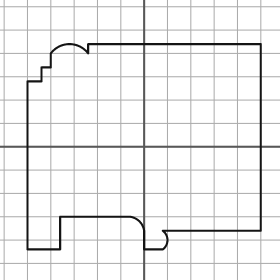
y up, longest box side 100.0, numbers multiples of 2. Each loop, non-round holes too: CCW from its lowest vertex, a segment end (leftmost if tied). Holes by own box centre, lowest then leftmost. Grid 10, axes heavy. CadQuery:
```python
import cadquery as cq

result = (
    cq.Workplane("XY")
    .moveTo(-50.0, -44.0)
    .lineTo(-36.0, -44.0)
    .lineTo(-36.0, -30.0)
    .lineTo(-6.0, -30.0)
    .threePointArc((-2.0, -32.0), (0.0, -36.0))
    .lineTo(0.0, -44.0)
    .lineTo(8.0, -44.0)
    .threePointArc((10.0, -40.0), (8.0, -36.0))
    .lineTo(50.0, -36.0)
    .lineTo(50.0, 44.0)
    .lineTo(-24.0, 44.0)
    .lineTo(-24.0, 40.0)
    .threePointArc((-32.0, 44.0), (-40.0, 40.0))
    .lineTo(-40.0, 34.0)
    .lineTo(-44.0, 34.0)
    .lineTo(-44.0, 28.0)
    .lineTo(-50.0, 28.0)
    .close()
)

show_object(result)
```